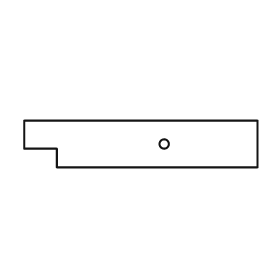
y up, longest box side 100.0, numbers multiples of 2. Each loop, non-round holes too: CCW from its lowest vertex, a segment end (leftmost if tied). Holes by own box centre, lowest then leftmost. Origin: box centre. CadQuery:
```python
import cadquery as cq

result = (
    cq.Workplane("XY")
    .moveTo(-36.0, -10.0)
    .lineTo(50.0, -10.0)
    .lineTo(50.0, 10.0)
    .lineTo(-50.0, 10.0)
    .lineTo(-50.0, -2.0)
    .lineTo(-36.0, -2.0)
    .close()
    .moveTo(10.0, 0.0)
    .circle(2.0)
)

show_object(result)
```